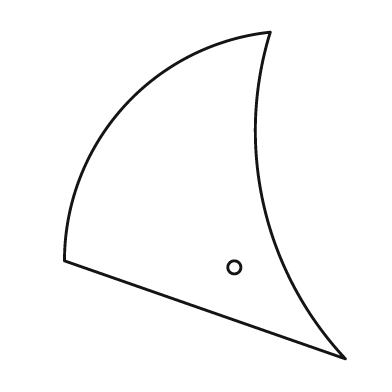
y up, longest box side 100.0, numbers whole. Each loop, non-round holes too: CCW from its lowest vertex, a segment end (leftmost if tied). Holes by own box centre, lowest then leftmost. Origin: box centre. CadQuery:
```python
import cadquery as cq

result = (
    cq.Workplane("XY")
    .moveTo(43.0, -50.0)
    .threePointArc((18.0, -3.0), (20.0, 50.0))
    .threePointArc((-25.0, 27.0), (-43.0, -20.0))
    .close()
    .moveTo(9.0, -22.0)
    .circle(2.0)
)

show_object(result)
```